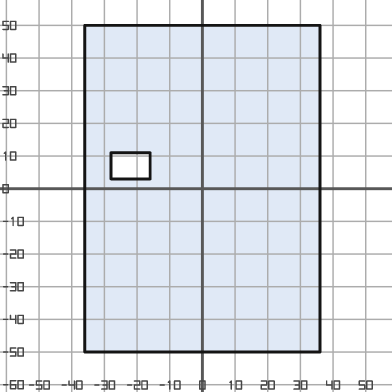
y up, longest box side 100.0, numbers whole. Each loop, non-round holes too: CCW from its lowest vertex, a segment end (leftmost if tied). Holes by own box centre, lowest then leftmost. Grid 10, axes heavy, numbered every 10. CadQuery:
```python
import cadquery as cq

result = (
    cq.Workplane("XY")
    .moveTo(-36.0, -50.0)
    .lineTo(36.0, -50.0)
    .lineTo(36.0, 50.0)
    .lineTo(-36.0, 50.0)
    .close()
    .moveTo(-28.0, 3.0)
    .lineTo(-16.0, 3.0)
    .lineTo(-16.0, 11.0)
    .lineTo(-28.0, 11.0)
    .close()
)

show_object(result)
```